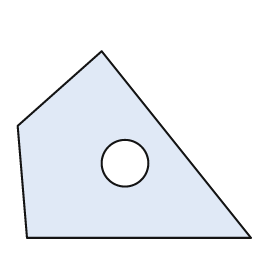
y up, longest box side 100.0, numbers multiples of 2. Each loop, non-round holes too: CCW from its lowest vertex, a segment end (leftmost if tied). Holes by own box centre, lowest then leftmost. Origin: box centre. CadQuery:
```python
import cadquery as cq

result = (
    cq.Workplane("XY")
    .moveTo(-46.0, -40.0)
    .lineTo(50.0, -40.0)
    .lineTo(-14.0, 40.0)
    .lineTo(-50.0, 8.0)
    .close()
    .moveTo(-4.0, -8.0)
    .circle(10.0)
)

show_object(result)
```